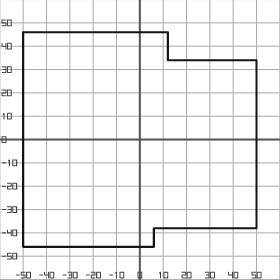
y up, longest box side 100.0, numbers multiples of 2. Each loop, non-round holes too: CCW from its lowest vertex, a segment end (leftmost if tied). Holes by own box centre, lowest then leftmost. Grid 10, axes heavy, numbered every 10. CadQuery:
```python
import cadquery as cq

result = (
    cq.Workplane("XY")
    .moveTo(-50.0, -46.0)
    .lineTo(6.0, -46.0)
    .lineTo(6.0, -38.0)
    .lineTo(50.0, -38.0)
    .lineTo(50.0, 34.0)
    .lineTo(12.0, 34.0)
    .lineTo(12.0, 46.0)
    .lineTo(-50.0, 46.0)
    .close()
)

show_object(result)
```